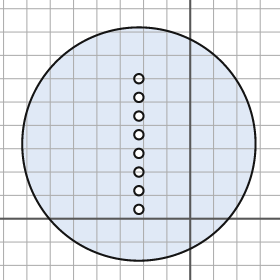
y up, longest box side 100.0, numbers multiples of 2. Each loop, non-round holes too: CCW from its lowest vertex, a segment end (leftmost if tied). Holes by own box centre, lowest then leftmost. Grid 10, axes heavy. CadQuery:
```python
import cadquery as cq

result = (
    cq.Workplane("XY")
    .moveTo(-22.0, 32.0)
    .circle(50.0)
    .moveTo(-22.0, 4.0)
    .circle(2.0)
    .moveTo(-22.0, 12.0)
    .circle(2.0)
    .moveTo(-22.0, 20.0)
    .circle(2.0)
    .moveTo(-22.0, 28.0)
    .circle(2.0)
    .moveTo(-22.0, 36.0)
    .circle(2.0)
    .moveTo(-22.0, 44.0)
    .circle(2.0)
    .moveTo(-22.0, 52.0)
    .circle(2.0)
    .moveTo(-22.0, 60.0)
    .circle(2.0)
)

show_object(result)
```